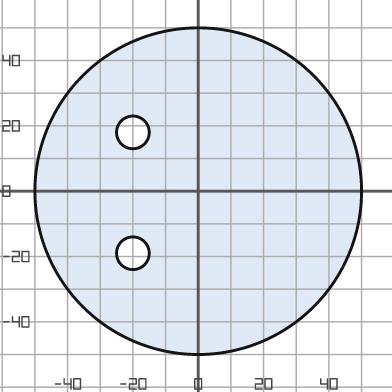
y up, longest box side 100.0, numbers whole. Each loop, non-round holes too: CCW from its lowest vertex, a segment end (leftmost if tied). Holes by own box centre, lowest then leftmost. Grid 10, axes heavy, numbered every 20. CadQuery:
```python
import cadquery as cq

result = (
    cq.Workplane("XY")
    .moveTo(0.0, 0.0)
    .circle(50.0)
    .moveTo(-20.0, -19.0)
    .circle(5.0)
    .moveTo(-20.0, 18.0)
    .circle(5.0)
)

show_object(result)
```